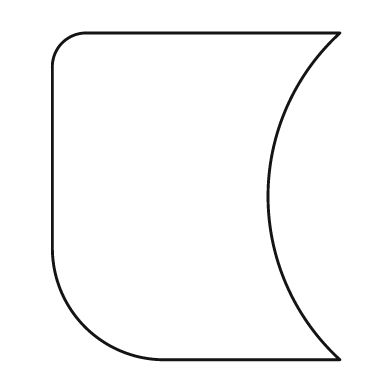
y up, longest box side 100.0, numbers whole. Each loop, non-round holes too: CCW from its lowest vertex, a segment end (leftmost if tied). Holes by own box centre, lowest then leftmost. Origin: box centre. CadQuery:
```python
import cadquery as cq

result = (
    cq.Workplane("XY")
    .moveTo(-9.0, -50.0)
    .lineTo(44.0, -50.0)
    .threePointArc((22.0, 0.0), (44.0, 50.0))
    .lineTo(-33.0, 50.0)
    .threePointArc((-41.0, 47.0), (-44.0, 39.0))
    .lineTo(-44.0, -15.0)
    .threePointArc((-34.0, -40.0), (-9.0, -50.0))
    .close()
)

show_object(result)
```